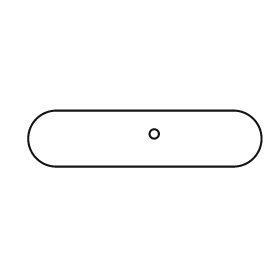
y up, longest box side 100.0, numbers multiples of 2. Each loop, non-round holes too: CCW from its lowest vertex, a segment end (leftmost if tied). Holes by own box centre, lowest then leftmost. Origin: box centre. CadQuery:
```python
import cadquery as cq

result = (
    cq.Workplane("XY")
    .moveTo(-38.0, -12.0)
    .lineTo(38.0, -12.0)
    .threePointArc((50.0, 0.0), (38.0, 12.0))
    .lineTo(-38.0, 12.0)
    .threePointArc((-50.0, 0.0), (-38.0, -12.0))
    .close()
    .moveTo(4.0, 2.0)
    .circle(2.0)
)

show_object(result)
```